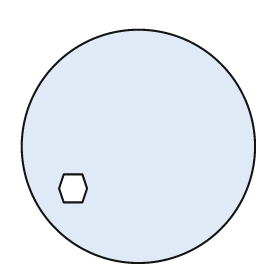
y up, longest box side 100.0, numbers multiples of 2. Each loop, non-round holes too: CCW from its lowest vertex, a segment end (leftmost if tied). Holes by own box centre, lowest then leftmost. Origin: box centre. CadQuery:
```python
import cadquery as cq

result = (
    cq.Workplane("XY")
    .moveTo(0.0, 0.0)
    .circle(50.0)
    .moveTo(-32.0, -24.0)
    .lineTo(-24.0, -24.0)
    .lineTo(-22.0, -18.0)
    .lineTo(-24.0, -12.0)
    .lineTo(-32.0, -12.0)
    .lineTo(-34.0, -18.0)
    .close()
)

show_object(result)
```